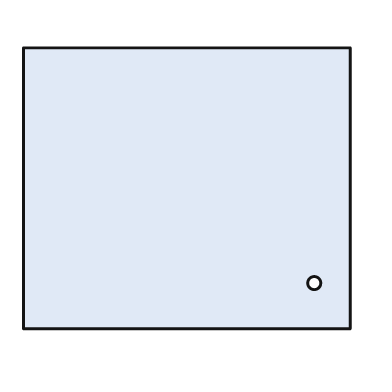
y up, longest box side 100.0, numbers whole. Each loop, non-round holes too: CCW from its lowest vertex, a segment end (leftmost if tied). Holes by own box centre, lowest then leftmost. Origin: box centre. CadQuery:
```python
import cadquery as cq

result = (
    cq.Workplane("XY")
    .moveTo(-50.0, -43.0)
    .lineTo(50.0, -43.0)
    .lineTo(50.0, 43.0)
    .lineTo(-50.0, 43.0)
    .close()
    .moveTo(39.0, -29.0)
    .circle(2.0)
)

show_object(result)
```